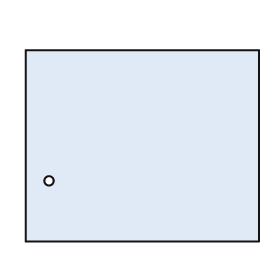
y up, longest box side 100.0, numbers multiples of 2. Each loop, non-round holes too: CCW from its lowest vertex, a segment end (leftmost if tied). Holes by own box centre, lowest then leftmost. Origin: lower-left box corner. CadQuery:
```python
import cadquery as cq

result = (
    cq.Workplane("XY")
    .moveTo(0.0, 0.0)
    .lineTo(100.0, 0.0)
    .lineTo(100.0, 82.0)
    .lineTo(0.0, 82.0)
    .close()
    .moveTo(10.0, 26.0)
    .circle(2.0)
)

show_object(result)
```